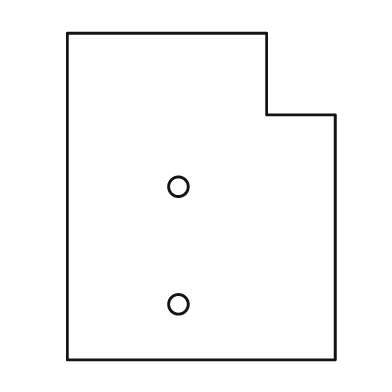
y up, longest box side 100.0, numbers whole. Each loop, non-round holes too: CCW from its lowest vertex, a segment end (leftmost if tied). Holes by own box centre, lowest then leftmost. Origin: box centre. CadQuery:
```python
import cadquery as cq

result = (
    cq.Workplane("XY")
    .moveTo(-41.0, -50.0)
    .lineTo(41.0, -50.0)
    .lineTo(41.0, 25.0)
    .lineTo(20.0, 25.0)
    .lineTo(20.0, 50.0)
    .lineTo(-41.0, 50.0)
    .close()
    .moveTo(-7.0, -33.0)
    .circle(3.0)
    .moveTo(-7.0, 3.0)
    .circle(3.0)
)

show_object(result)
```